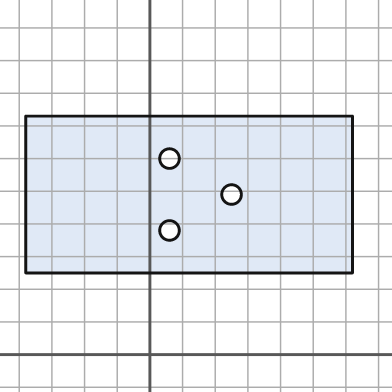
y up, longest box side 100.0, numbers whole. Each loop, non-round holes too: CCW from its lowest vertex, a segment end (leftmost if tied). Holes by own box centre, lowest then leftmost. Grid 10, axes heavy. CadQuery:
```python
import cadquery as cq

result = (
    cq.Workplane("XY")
    .moveTo(-38.0, 25.0)
    .lineTo(62.0, 25.0)
    .lineTo(62.0, 73.0)
    .lineTo(-38.0, 73.0)
    .close()
    .moveTo(6.0, 38.0)
    .circle(3.0)
    .moveTo(25.0, 49.0)
    .circle(3.0)
    .moveTo(6.0, 60.0)
    .circle(3.0)
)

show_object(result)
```